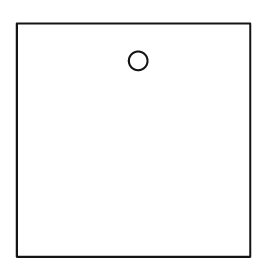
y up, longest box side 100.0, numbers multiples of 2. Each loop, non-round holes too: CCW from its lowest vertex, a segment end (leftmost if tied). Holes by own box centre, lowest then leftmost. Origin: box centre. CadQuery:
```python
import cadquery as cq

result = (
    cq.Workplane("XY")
    .moveTo(-50.0, -50.0)
    .lineTo(50.0, -50.0)
    .lineTo(50.0, 50.0)
    .lineTo(-50.0, 50.0)
    .close()
    .moveTo(2.0, 34.0)
    .circle(4.0)
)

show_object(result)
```